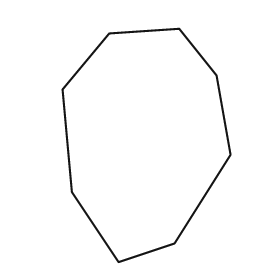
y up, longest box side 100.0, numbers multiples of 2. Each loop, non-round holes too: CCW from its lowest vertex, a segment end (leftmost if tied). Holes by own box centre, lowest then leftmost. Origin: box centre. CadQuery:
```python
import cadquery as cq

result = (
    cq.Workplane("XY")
    .moveTo(-12.0, -50.0)
    .lineTo(12.0, -42.0)
    .lineTo(36.0, -4.0)
    .lineTo(30.0, 30.0)
    .lineTo(14.0, 50.0)
    .lineTo(-16.0, 48.0)
    .lineTo(-36.0, 24.0)
    .lineTo(-32.0, -20.0)
    .close()
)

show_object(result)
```